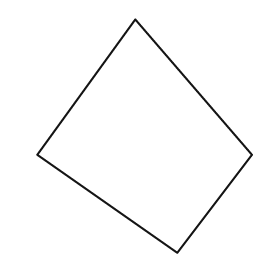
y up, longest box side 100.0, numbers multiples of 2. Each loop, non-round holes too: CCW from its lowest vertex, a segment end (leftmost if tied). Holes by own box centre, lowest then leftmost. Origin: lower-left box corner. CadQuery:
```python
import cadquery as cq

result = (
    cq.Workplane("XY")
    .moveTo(60.0, 0.0)
    .lineTo(92.0, 42.0)
    .lineTo(42.0, 100.0)
    .lineTo(0.0, 42.0)
    .close()
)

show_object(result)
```